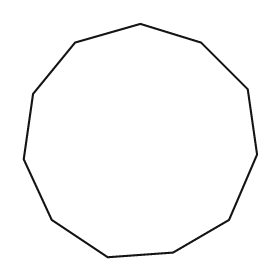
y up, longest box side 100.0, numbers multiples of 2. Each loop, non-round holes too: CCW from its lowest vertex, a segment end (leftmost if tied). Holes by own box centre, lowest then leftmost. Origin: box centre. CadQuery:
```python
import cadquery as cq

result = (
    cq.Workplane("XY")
    .moveTo(-14.0, -50.0)
    .lineTo(14.0, -48.0)
    .lineTo(38.0, -34.0)
    .lineTo(50.0, -6.0)
    .lineTo(46.0, 22.0)
    .lineTo(26.0, 42.0)
    .lineTo(0.0, 50.0)
    .lineTo(-28.0, 42.0)
    .lineTo(-46.0, 20.0)
    .lineTo(-50.0, -8.0)
    .lineTo(-38.0, -34.0)
    .close()
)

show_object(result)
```